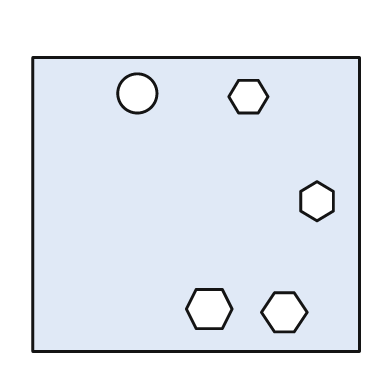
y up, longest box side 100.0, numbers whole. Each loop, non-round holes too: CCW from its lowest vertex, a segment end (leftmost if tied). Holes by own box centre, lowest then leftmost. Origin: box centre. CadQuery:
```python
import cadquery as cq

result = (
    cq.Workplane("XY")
    .moveTo(-50.0, -45.0)
    .lineTo(50.0, -45.0)
    .lineTo(50.0, 45.0)
    .lineTo(-50.0, 45.0)
    .close()
    .moveTo(24.0, -39.0)
    .lineTo(30.0, -39.0)
    .lineTo(34.0, -33.0)
    .lineTo(30.0, -27.0)
    .lineTo(24.0, -27.0)
    .lineTo(20.0, -33.0)
    .close()
    .moveTo(0.0, -38.0)
    .lineTo(8.0, -38.0)
    .lineTo(11.0, -32.0)
    .lineTo(8.0, -26.0)
    .lineTo(0.0, -26.0)
    .lineTo(-3.0, -32.0)
    .close()
    .moveTo(37.0, -5.0)
    .lineTo(42.0, -2.0)
    .lineTo(42.0, 4.0)
    .lineTo(37.0, 7.0)
    .lineTo(32.0, 4.0)
    .lineTo(32.0, -2.0)
    .close()
    .moveTo(13.0, 28.0)
    .lineTo(19.0, 28.0)
    .lineTo(22.0, 33.0)
    .lineTo(19.0, 38.0)
    .lineTo(13.0, 38.0)
    .lineTo(10.0, 33.0)
    .close()
    .moveTo(-18.0, 34.0)
    .circle(6.0)
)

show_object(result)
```